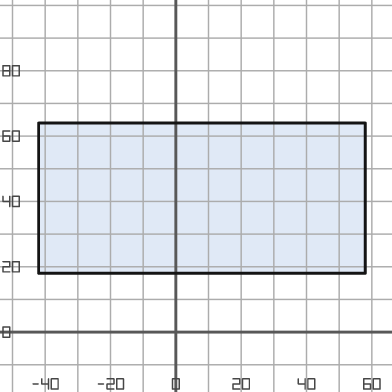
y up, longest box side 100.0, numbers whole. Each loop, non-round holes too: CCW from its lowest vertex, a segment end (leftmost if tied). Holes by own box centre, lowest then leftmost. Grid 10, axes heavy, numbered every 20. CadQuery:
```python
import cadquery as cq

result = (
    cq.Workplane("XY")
    .moveTo(-42.0, 18.0)
    .lineTo(58.0, 18.0)
    .lineTo(58.0, 64.0)
    .lineTo(-42.0, 64.0)
    .close()
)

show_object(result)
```